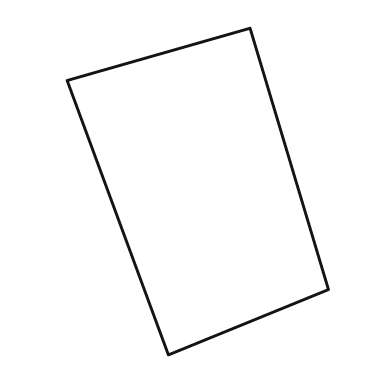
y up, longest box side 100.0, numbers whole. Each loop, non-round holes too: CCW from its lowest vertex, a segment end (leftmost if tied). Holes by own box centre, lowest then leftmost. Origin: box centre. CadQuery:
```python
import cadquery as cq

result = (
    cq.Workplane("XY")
    .moveTo(-9.0, -50.0)
    .lineTo(40.0, -30.0)
    .lineTo(16.0, 50.0)
    .lineTo(-40.0, 34.0)
    .close()
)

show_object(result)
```